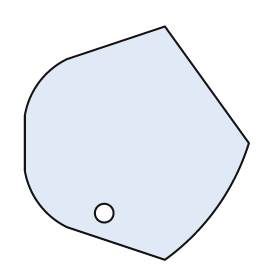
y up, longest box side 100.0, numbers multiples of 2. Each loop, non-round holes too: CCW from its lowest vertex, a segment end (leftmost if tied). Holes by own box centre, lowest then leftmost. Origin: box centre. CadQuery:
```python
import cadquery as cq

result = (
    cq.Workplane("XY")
    .moveTo(12.0, -50.0)
    .threePointArc((34.0, -28.0), (48.0, 0.0))
    .lineTo(12.0, 50.0)
    .lineTo(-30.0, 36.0)
    .threePointArc((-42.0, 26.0), (-48.0, 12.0))
    .lineTo(-48.0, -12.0)
    .threePointArc((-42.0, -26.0), (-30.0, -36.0))
    .close()
    .moveTo(-14.0, -30.0)
    .circle(4.0)
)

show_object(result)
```